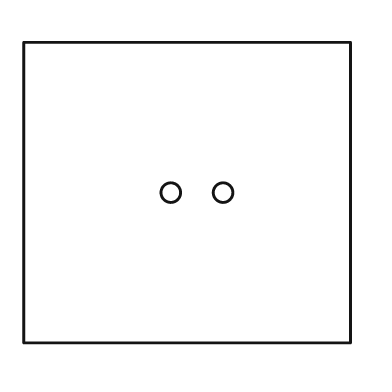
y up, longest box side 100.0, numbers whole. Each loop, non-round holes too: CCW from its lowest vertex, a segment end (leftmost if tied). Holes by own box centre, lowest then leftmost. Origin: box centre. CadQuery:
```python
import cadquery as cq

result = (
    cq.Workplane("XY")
    .moveTo(-50.0, -46.0)
    .lineTo(50.0, -46.0)
    .lineTo(50.0, 46.0)
    .lineTo(-50.0, 46.0)
    .close()
    .moveTo(-5.0, 0.0)
    .circle(3.0)
    .moveTo(11.0, 0.0)
    .circle(3.0)
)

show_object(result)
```